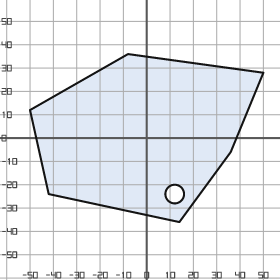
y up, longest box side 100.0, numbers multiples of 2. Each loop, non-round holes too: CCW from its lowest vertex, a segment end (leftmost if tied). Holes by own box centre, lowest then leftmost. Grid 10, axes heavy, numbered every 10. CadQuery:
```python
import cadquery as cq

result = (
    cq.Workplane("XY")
    .moveTo(14.0, -36.0)
    .lineTo(36.0, -6.0)
    .lineTo(50.0, 28.0)
    .lineTo(-8.0, 36.0)
    .lineTo(-50.0, 12.0)
    .lineTo(-42.0, -24.0)
    .close()
    .moveTo(12.0, -24.0)
    .circle(4.0)
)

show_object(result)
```